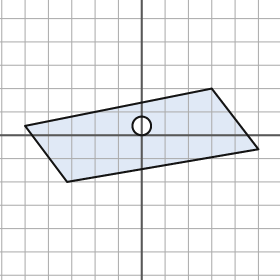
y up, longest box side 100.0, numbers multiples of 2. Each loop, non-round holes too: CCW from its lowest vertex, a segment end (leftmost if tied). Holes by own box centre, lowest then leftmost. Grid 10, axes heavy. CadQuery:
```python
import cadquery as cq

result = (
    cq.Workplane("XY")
    .moveTo(-32.0, -20.0)
    .lineTo(50.0, -6.0)
    .lineTo(30.0, 20.0)
    .lineTo(-50.0, 4.0)
    .close()
    .moveTo(0.0, 4.0)
    .circle(4.0)
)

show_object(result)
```